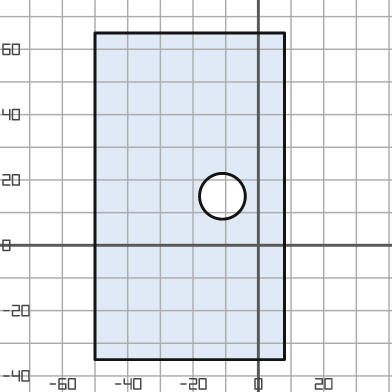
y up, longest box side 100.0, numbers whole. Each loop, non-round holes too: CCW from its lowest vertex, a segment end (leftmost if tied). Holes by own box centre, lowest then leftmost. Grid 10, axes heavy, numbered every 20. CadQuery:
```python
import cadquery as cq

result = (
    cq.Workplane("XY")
    .moveTo(-50.0, -35.0)
    .lineTo(8.0, -35.0)
    .lineTo(8.0, 65.0)
    .lineTo(-50.0, 65.0)
    .close()
    .moveTo(-11.0, 15.0)
    .circle(7.0)
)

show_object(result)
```